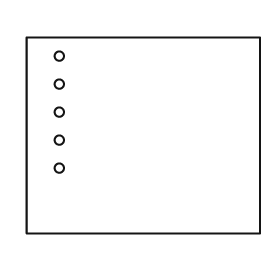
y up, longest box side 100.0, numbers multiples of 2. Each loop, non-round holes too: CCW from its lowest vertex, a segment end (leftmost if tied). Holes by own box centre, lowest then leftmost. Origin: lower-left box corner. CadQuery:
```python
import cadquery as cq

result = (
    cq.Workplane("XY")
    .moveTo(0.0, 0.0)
    .lineTo(100.0, 0.0)
    .lineTo(100.0, 84.0)
    .lineTo(0.0, 84.0)
    .close()
    .moveTo(14.0, 28.0)
    .circle(2.0)
    .moveTo(14.0, 40.0)
    .circle(2.0)
    .moveTo(14.0, 52.0)
    .circle(2.0)
    .moveTo(14.0, 64.0)
    .circle(2.0)
    .moveTo(14.0, 76.0)
    .circle(2.0)
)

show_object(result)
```